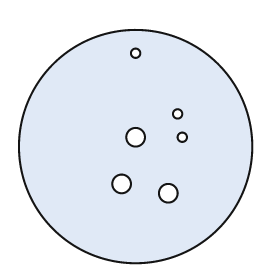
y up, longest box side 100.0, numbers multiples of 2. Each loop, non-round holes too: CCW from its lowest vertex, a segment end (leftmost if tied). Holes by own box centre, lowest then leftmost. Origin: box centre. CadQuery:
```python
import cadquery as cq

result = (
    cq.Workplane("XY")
    .moveTo(0.0, 0.0)
    .circle(50.0)
    .moveTo(14.0, -20.0)
    .circle(4.0)
    .moveTo(-6.0, -16.0)
    .circle(4.0)
    .moveTo(0.0, 4.0)
    .circle(4.0)
    .moveTo(20.0, 4.0)
    .circle(2.0)
    .moveTo(18.0, 14.0)
    .circle(2.0)
    .moveTo(0.0, 40.0)
    .circle(2.0)
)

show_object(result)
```